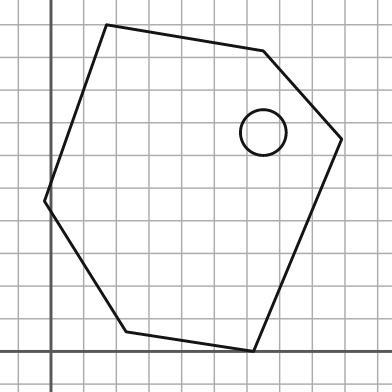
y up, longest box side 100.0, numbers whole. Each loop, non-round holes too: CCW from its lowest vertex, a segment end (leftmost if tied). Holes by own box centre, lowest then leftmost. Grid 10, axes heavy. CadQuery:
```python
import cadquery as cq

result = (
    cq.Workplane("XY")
    .moveTo(62.0, 0.0)
    .lineTo(89.0, 65.0)
    .lineTo(65.0, 92.0)
    .lineTo(17.0, 100.0)
    .lineTo(-2.0, 46.0)
    .lineTo(23.0, 6.0)
    .close()
    .moveTo(65.0, 67.0)
    .circle(7.0)
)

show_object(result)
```